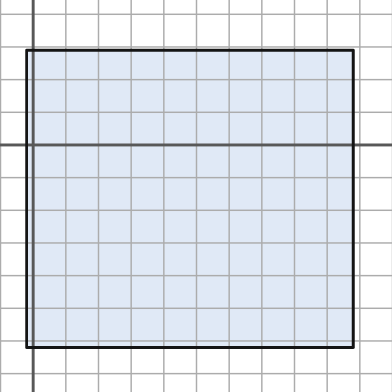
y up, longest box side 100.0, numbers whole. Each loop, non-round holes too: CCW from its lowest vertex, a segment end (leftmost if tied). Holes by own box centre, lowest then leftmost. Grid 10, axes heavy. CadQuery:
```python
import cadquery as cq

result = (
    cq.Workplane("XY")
    .moveTo(-2.0, -62.0)
    .lineTo(98.0, -62.0)
    .lineTo(98.0, 29.0)
    .lineTo(-2.0, 29.0)
    .close()
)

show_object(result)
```